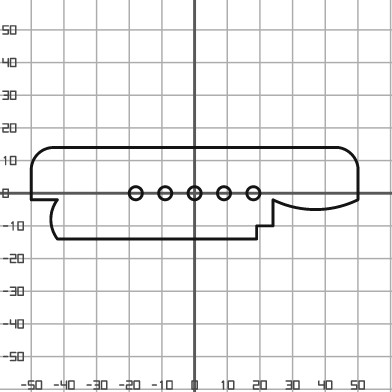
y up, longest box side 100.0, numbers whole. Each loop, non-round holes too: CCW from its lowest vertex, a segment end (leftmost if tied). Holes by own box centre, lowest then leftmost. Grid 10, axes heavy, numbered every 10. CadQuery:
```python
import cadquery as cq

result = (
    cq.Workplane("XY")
    .moveTo(-42.0, -14.0)
    .lineTo(19.0, -14.0)
    .lineTo(19.0, -10.0)
    .lineTo(24.0, -10.0)
    .lineTo(24.0, -2.0)
    .threePointArc((37.0, -5.0), (50.0, -2.0))
    .lineTo(50.0, 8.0)
    .threePointArc((48.0, 12.0), (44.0, 14.0))
    .lineTo(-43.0, 14.0)
    .threePointArc((-48.0, 12.0), (-50.0, 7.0))
    .lineTo(-50.0, -2.0)
    .lineTo(-42.0, -2.0)
    .threePointArc((-44.0, -8.0), (-42.0, -14.0))
    .close()
    .moveTo(-18.0, 0.0)
    .circle(2.0)
    .moveTo(-9.0, 0.0)
    .circle(2.0)
    .moveTo(0.0, 0.0)
    .circle(2.0)
    .moveTo(9.0, 0.0)
    .circle(2.0)
    .moveTo(18.0, 0.0)
    .circle(2.0)
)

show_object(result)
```